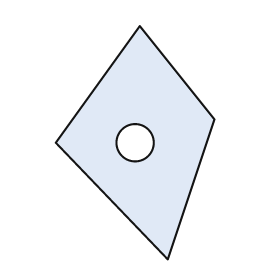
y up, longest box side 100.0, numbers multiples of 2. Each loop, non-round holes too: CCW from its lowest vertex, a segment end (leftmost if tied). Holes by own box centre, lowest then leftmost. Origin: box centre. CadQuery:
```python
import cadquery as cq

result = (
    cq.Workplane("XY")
    .moveTo(14.0, -50.0)
    .lineTo(34.0, 10.0)
    .lineTo(2.0, 50.0)
    .lineTo(-34.0, 0.0)
    .close()
    .moveTo(0.0, 0.0)
    .circle(8.0)
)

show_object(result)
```